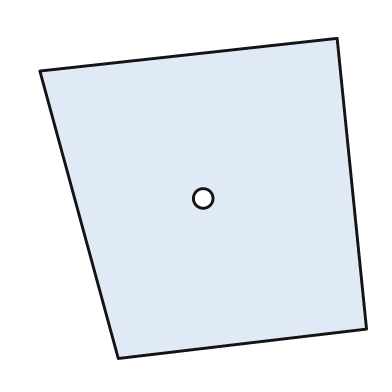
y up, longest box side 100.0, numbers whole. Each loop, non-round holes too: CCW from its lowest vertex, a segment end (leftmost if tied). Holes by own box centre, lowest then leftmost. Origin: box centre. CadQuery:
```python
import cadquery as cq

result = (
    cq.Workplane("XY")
    .moveTo(-26.0, -49.0)
    .lineTo(50.0, -40.0)
    .lineTo(41.0, 49.0)
    .lineTo(-50.0, 39.0)
    .close()
    .moveTo(0.0, 0.0)
    .circle(3.0)
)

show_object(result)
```